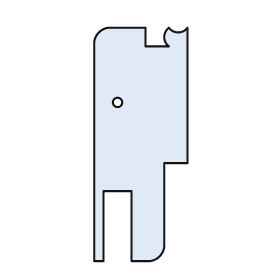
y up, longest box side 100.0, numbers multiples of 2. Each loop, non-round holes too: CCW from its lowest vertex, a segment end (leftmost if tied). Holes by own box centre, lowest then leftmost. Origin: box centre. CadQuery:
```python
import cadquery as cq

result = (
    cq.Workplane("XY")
    .moveTo(-20.0, -50.0)
    .lineTo(-16.0, -50.0)
    .lineTo(-16.0, -20.0)
    .lineTo(-4.0, -20.0)
    .lineTo(-4.0, -50.0)
    .lineTo(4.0, -50.0)
    .threePointArc((8.0, -48.0), (10.0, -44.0))
    .lineTo(10.0, -8.0)
    .lineTo(20.0, -8.0)
    .lineTo(20.0, 50.0)
    .threePointArc((16.0, 48.0), (12.0, 50.0))
    .threePointArc((10.0, 46.0), (12.0, 42.0))
    .lineTo(2.0, 42.0)
    .lineTo(2.0, 50.0)
    .lineTo(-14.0, 50.0)
    .threePointArc((-18.0, 48.0), (-20.0, 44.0))
    .close()
    .moveTo(-10.0, 18.0)
    .circle(2.0)
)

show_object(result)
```